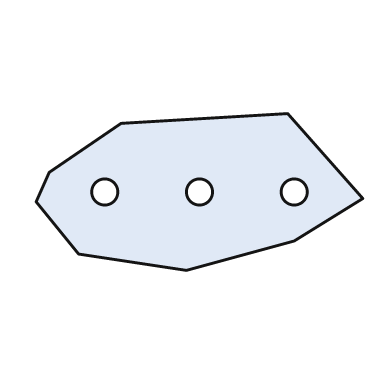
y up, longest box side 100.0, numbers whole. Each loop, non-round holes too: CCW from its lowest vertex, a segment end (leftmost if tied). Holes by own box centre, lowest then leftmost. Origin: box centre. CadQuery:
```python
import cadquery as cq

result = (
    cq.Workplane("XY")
    .moveTo(-4.0, -24.0)
    .lineTo(29.0, -15.0)
    .lineTo(50.0, -2.0)
    .lineTo(27.0, 24.0)
    .lineTo(-24.0, 21.0)
    .lineTo(-46.0, 6.0)
    .lineTo(-50.0, -3.0)
    .lineTo(-37.0, -19.0)
    .close()
    .moveTo(-29.0, 0.0)
    .circle(4.0)
    .moveTo(0.0, 0.0)
    .circle(4.0)
    .moveTo(29.0, 0.0)
    .circle(4.0)
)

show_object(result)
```